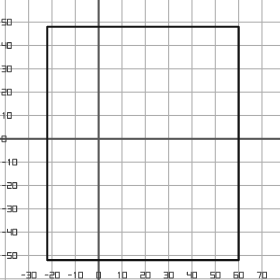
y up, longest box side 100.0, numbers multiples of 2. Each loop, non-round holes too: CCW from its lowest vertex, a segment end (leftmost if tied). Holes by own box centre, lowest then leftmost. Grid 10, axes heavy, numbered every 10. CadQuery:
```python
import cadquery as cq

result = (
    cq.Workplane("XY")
    .moveTo(-22.0, -52.0)
    .lineTo(60.0, -52.0)
    .lineTo(60.0, 48.0)
    .lineTo(-22.0, 48.0)
    .close()
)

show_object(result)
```